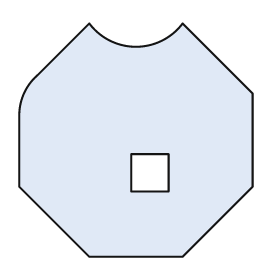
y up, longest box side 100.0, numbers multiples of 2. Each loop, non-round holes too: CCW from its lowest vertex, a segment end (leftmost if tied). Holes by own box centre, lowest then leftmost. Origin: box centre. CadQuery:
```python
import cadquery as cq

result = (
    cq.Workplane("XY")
    .moveTo(-20.0, -50.0)
    .lineTo(20.0, -50.0)
    .lineTo(50.0, -20.0)
    .lineTo(50.0, 20.0)
    .lineTo(20.0, 50.0)
    .threePointArc((0.0, 40.0), (-20.0, 50.0))
    .lineTo(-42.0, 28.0)
    .threePointArc((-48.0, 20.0), (-50.0, 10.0))
    .lineTo(-50.0, -20.0)
    .close()
    .moveTo(-2.0, -22.0)
    .lineTo(14.0, -22.0)
    .lineTo(14.0, -6.0)
    .lineTo(-2.0, -6.0)
    .close()
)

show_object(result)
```